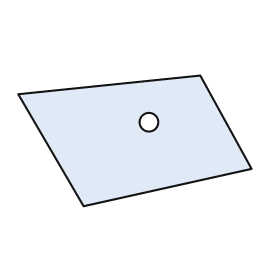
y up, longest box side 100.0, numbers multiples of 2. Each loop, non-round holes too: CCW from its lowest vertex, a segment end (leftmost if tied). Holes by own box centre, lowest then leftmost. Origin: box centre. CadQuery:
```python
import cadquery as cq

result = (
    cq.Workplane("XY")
    .moveTo(-22.0, -28.0)
    .lineTo(50.0, -12.0)
    .lineTo(28.0, 28.0)
    .lineTo(-50.0, 20.0)
    .close()
    .moveTo(6.0, 8.0)
    .circle(4.0)
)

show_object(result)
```